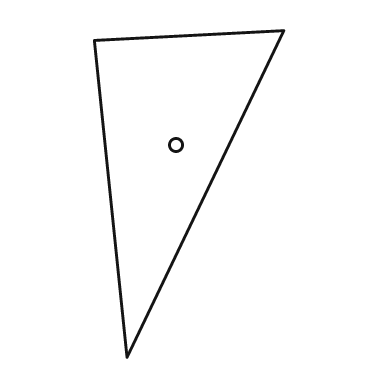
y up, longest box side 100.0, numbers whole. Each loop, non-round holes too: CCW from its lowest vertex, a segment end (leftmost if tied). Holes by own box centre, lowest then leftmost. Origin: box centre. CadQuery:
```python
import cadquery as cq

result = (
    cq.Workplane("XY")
    .moveTo(-19.0, -50.0)
    .lineTo(29.0, 50.0)
    .lineTo(-29.0, 47.0)
    .close()
    .moveTo(-4.0, 15.0)
    .circle(2.0)
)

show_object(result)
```